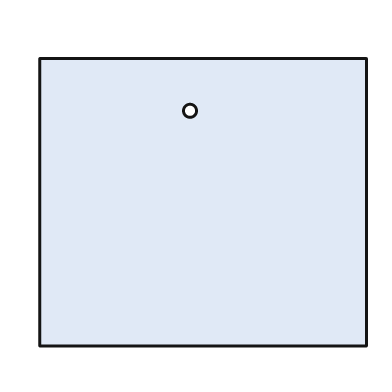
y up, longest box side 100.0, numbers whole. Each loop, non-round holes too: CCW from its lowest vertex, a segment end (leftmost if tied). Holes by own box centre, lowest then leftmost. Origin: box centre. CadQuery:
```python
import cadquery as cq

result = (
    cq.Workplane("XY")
    .moveTo(-50.0, -44.0)
    .lineTo(50.0, -44.0)
    .lineTo(50.0, 44.0)
    .lineTo(-50.0, 44.0)
    .close()
    .moveTo(-4.0, 28.0)
    .circle(2.0)
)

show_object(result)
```